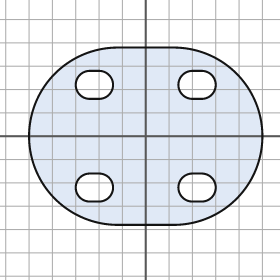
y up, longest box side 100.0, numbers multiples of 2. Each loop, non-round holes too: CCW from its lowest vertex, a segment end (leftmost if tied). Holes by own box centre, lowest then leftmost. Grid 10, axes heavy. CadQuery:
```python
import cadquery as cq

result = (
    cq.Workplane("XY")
    .moveTo(-12.0, -38.0)
    .lineTo(12.0, -38.0)
    .threePointArc((50.0, 0.0), (12.0, 38.0))
    .lineTo(-12.0, 38.0)
    .threePointArc((-50.0, 0.0), (-12.0, -38.0))
    .close()
    .moveTo(-24.0, -28.0)
    .lineTo(-20.0, -28.0)
    .threePointArc((-14.0, -22.0), (-20.0, -16.0))
    .lineTo(-24.0, -16.0)
    .threePointArc((-30.0, -22.0), (-24.0, -28.0))
    .close()
    .moveTo(20.0, -28.0)
    .lineTo(24.0, -28.0)
    .threePointArc((30.0, -22.0), (24.0, -16.0))
    .lineTo(20.0, -16.0)
    .threePointArc((14.0, -22.0), (20.0, -28.0))
    .close()
    .moveTo(-24.0, 16.0)
    .lineTo(-20.0, 16.0)
    .threePointArc((-14.0, 22.0), (-20.0, 28.0))
    .lineTo(-24.0, 28.0)
    .threePointArc((-30.0, 22.0), (-24.0, 16.0))
    .close()
    .moveTo(20.0, 16.0)
    .lineTo(24.0, 16.0)
    .threePointArc((30.0, 22.0), (24.0, 28.0))
    .lineTo(20.0, 28.0)
    .threePointArc((14.0, 22.0), (20.0, 16.0))
    .close()
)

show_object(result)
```